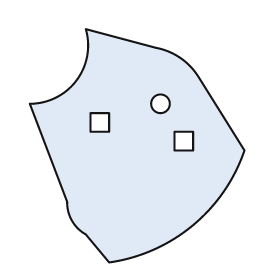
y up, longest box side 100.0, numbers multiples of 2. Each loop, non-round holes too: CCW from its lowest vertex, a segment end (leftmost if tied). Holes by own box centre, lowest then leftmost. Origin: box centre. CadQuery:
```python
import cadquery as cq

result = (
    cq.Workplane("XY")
    .moveTo(-12.0, -50.0)
    .threePointArc((24.0, -34.0), (46.0, -2.0))
    .lineTo(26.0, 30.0)
    .threePointArc((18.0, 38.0), (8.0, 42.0))
    .lineTo(-22.0, 50.0)
    .threePointArc((-26.0, 28.0), (-46.0, 18.0))
    .lineTo(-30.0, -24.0)
    .threePointArc((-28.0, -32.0), (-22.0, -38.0))
    .close()
    .moveTo(16.0, -2.0)
    .lineTo(24.0, -2.0)
    .lineTo(24.0, 6.0)
    .lineTo(16.0, 6.0)
    .close()
    .moveTo(-20.0, 6.0)
    .lineTo(-12.0, 6.0)
    .lineTo(-12.0, 14.0)
    .lineTo(-20.0, 14.0)
    .close()
    .moveTo(10.0, 18.0)
    .circle(4.0)
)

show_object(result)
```